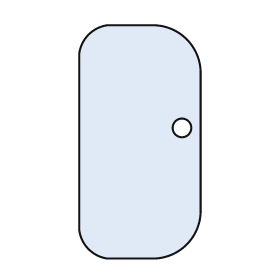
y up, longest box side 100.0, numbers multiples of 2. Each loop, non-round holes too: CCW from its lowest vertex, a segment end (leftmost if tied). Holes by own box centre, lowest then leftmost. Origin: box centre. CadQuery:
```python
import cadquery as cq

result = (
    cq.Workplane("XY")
    .moveTo(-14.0, -50.0)
    .lineTo(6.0, -50.0)
    .threePointArc((20.0, -44.0), (26.0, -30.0))
    .lineTo(26.0, 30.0)
    .threePointArc((20.0, 44.0), (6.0, 50.0))
    .lineTo(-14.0, 50.0)
    .threePointArc((-22.0, 46.0), (-26.0, 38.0))
    .lineTo(-26.0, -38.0)
    .threePointArc((-22.0, -46.0), (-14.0, -50.0))
    .close()
    .moveTo(18.0, 6.0)
    .circle(4.0)
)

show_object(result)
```